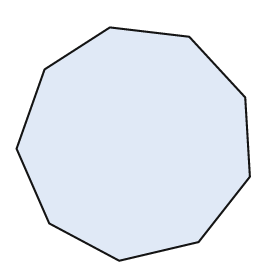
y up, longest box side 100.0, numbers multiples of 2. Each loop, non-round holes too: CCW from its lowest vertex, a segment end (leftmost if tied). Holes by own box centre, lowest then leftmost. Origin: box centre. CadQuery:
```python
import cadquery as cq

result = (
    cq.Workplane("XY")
    .moveTo(-6.0, -50.0)
    .lineTo(28.0, -42.0)
    .lineTo(50.0, -14.0)
    .lineTo(48.0, 20.0)
    .lineTo(24.0, 46.0)
    .lineTo(-10.0, 50.0)
    .lineTo(-38.0, 32.0)
    .lineTo(-50.0, -2.0)
    .lineTo(-36.0, -34.0)
    .close()
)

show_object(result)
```